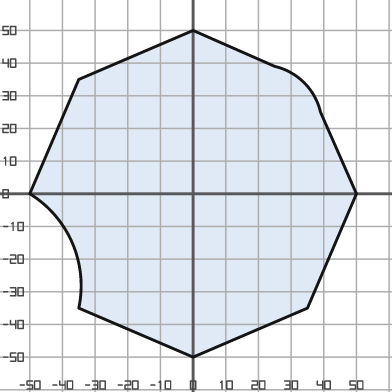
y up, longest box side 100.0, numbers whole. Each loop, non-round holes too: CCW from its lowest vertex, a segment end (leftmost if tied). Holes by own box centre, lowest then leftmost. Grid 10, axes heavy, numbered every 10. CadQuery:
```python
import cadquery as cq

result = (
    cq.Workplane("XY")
    .moveTo(0.0, -50.0)
    .lineTo(35.0, -35.0)
    .lineTo(50.0, 0.0)
    .lineTo(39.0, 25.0)
    .threePointArc((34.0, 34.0), (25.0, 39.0))
    .lineTo(0.0, 50.0)
    .lineTo(-35.0, 35.0)
    .lineTo(-50.0, 0.0)
    .threePointArc((-37.0, -15.0), (-35.0, -35.0))
    .close()
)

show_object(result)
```